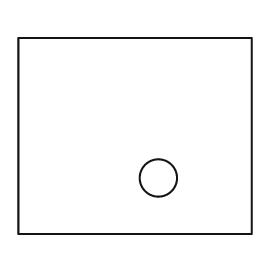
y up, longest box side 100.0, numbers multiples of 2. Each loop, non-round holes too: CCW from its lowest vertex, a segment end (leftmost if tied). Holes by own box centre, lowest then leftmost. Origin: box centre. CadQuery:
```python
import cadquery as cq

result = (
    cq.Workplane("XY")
    .moveTo(-50.0, -42.0)
    .lineTo(50.0, -42.0)
    .lineTo(50.0, 42.0)
    .lineTo(-50.0, 42.0)
    .close()
    .moveTo(10.0, -18.0)
    .circle(8.0)
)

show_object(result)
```